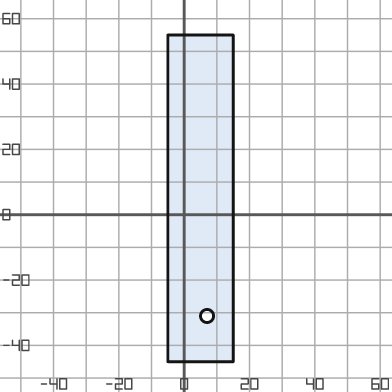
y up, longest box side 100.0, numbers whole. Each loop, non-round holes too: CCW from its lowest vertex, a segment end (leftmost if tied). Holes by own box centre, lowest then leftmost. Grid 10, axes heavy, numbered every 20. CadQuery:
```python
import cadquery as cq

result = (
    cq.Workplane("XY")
    .moveTo(-5.0, -45.0)
    .lineTo(15.0, -45.0)
    .lineTo(15.0, 55.0)
    .lineTo(-5.0, 55.0)
    .close()
    .moveTo(7.0, -31.0)
    .circle(2.0)
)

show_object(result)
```